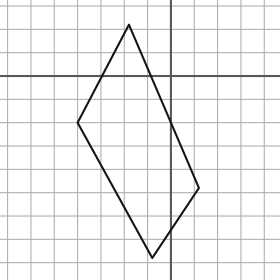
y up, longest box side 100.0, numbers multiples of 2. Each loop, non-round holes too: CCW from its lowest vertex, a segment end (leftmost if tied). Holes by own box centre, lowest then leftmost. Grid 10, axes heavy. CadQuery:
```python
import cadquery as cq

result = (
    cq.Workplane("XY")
    .moveTo(-8.0, -78.0)
    .lineTo(12.0, -48.0)
    .lineTo(-18.0, 22.0)
    .lineTo(-40.0, -20.0)
    .close()
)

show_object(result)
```